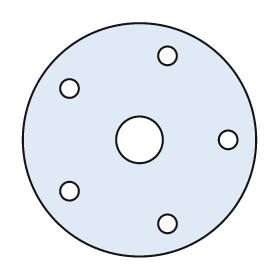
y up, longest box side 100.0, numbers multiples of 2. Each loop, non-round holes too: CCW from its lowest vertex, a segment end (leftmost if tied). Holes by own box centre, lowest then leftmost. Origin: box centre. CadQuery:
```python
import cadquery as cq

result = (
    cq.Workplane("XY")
    .moveTo(0.0, 0.0)
    .circle(50.0)
    .moveTo(12.0, -36.0)
    .circle(4.0)
    .moveTo(-30.0, -22.0)
    .circle(4.0)
    .moveTo(0.0, 0.0)
    .circle(10.0)
    .moveTo(38.0, 0.0)
    .circle(4.0)
    .moveTo(-30.0, 22.0)
    .circle(4.0)
    .moveTo(12.0, 36.0)
    .circle(4.0)
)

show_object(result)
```